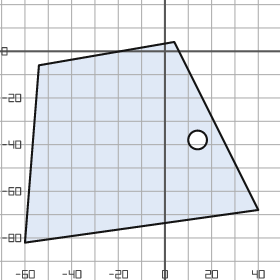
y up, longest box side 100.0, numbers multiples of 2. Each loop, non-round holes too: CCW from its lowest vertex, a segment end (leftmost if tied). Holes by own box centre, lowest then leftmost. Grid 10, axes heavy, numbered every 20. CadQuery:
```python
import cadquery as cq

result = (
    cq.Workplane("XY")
    .moveTo(-60.0, -82.0)
    .lineTo(40.0, -68.0)
    .lineTo(4.0, 4.0)
    .lineTo(-54.0, -6.0)
    .close()
    .moveTo(14.0, -38.0)
    .circle(4.0)
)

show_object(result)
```